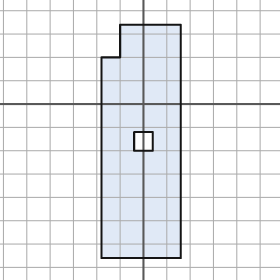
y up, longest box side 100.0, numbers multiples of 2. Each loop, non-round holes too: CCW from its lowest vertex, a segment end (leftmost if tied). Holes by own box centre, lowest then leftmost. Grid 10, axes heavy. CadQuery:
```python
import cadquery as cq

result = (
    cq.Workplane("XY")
    .moveTo(-18.0, -66.0)
    .lineTo(16.0, -66.0)
    .lineTo(16.0, 34.0)
    .lineTo(-10.0, 34.0)
    .lineTo(-10.0, 20.0)
    .lineTo(-18.0, 20.0)
    .close()
    .moveTo(-4.0, -20.0)
    .lineTo(4.0, -20.0)
    .lineTo(4.0, -12.0)
    .lineTo(-4.0, -12.0)
    .close()
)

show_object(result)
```